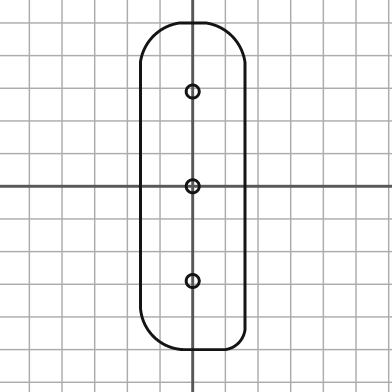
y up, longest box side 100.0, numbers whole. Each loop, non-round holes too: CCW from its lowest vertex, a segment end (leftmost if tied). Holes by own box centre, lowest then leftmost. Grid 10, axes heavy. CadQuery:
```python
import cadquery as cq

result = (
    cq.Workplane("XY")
    .moveTo(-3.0, -50.0)
    .lineTo(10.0, -50.0)
    .threePointArc((14.0, -48.0), (16.0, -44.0))
    .lineTo(16.0, 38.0)
    .threePointArc((12.0, 46.0), (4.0, 50.0))
    .lineTo(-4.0, 50.0)
    .threePointArc((-12.0, 46.0), (-16.0, 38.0))
    .lineTo(-16.0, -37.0)
    .threePointArc((-12.0, -46.0), (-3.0, -50.0))
    .close()
    .moveTo(0.0, -29.0)
    .circle(2.0)
    .moveTo(0.0, 0.0)
    .circle(2.0)
    .moveTo(0.0, 29.0)
    .circle(2.0)
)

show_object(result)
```